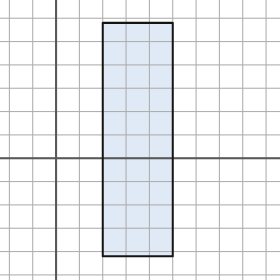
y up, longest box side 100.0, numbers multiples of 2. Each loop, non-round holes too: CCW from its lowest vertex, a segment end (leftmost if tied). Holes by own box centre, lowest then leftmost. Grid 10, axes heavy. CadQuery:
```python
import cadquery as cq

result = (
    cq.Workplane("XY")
    .moveTo(20.0, -42.0)
    .lineTo(50.0, -42.0)
    .lineTo(50.0, 58.0)
    .lineTo(20.0, 58.0)
    .close()
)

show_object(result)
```